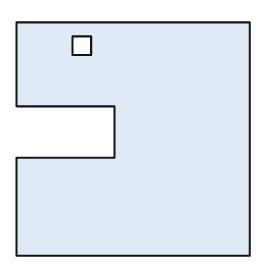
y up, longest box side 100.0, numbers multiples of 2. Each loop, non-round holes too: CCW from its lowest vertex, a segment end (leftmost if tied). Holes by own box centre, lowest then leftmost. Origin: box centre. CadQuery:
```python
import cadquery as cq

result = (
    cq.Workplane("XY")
    .moveTo(-50.0, -50.0)
    .lineTo(50.0, -50.0)
    .lineTo(50.0, 50.0)
    .lineTo(-50.0, 50.0)
    .lineTo(-50.0, 14.0)
    .lineTo(-8.0, 14.0)
    .lineTo(-8.0, -8.0)
    .lineTo(-50.0, -8.0)
    .close()
    .moveTo(-26.0, 36.0)
    .lineTo(-18.0, 36.0)
    .lineTo(-18.0, 44.0)
    .lineTo(-26.0, 44.0)
    .close()
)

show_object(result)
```